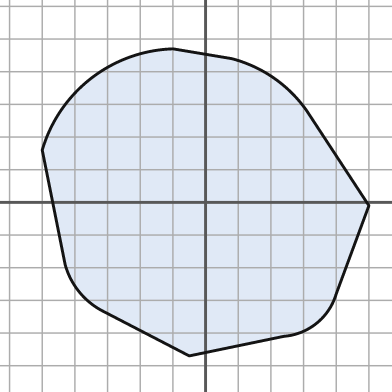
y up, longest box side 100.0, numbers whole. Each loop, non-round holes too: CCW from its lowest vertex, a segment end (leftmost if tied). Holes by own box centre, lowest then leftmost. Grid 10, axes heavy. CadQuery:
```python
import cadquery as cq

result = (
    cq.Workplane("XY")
    .moveTo(-5.0, -47.0)
    .lineTo(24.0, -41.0)
    .threePointArc((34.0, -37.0), (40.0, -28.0))
    .lineTo(50.0, -1.0)
    .lineTo(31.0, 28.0)
    .threePointArc((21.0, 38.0), (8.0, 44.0))
    .lineTo(-10.0, 47.0)
    .threePointArc((-35.0, 38.0), (-50.0, 16.0))
    .lineTo(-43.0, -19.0)
    .threePointArc((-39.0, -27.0), (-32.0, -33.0))
    .close()
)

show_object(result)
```